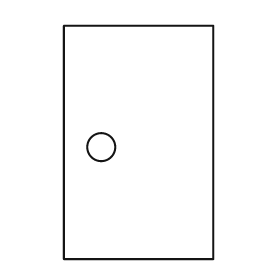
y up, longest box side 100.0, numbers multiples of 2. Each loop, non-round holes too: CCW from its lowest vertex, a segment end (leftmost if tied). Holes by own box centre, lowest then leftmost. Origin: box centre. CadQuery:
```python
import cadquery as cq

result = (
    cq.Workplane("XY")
    .moveTo(-32.0, -50.0)
    .lineTo(32.0, -50.0)
    .lineTo(32.0, 50.0)
    .lineTo(-32.0, 50.0)
    .close()
    .moveTo(-16.0, -2.0)
    .circle(6.0)
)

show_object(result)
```